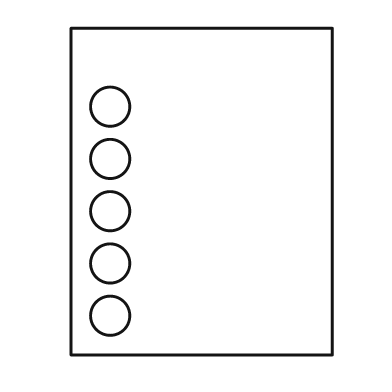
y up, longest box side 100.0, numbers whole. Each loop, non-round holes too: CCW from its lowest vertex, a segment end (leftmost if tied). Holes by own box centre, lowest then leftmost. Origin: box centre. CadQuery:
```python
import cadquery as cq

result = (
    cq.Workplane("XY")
    .moveTo(-40.0, -50.0)
    .lineTo(40.0, -50.0)
    .lineTo(40.0, 50.0)
    .lineTo(-40.0, 50.0)
    .close()
    .moveTo(-28.0, -38.0)
    .circle(6.0)
    .moveTo(-28.0, -22.0)
    .circle(6.0)
    .moveTo(-28.0, -6.0)
    .circle(6.0)
    .moveTo(-28.0, 10.0)
    .circle(6.0)
    .moveTo(-28.0, 26.0)
    .circle(6.0)
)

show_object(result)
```